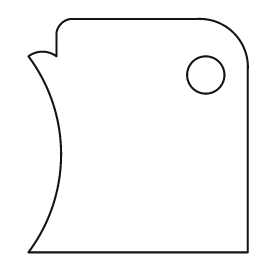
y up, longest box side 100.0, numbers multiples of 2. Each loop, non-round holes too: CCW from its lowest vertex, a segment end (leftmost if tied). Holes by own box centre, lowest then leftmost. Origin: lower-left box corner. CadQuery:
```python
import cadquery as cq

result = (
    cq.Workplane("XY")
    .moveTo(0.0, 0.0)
    .lineTo(94.0, 0.0)
    .lineTo(94.0, 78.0)
    .threePointArc((88.0, 94.0), (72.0, 100.0))
    .lineTo(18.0, 100.0)
    .threePointArc((14.0, 98.0), (12.0, 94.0))
    .lineTo(12.0, 84.0)
    .threePointArc((6.0, 86.0), (0.0, 84.0))
    .threePointArc((14.0, 42.0), (0.0, 0.0))
    .close()
    .moveTo(76.0, 76.0)
    .circle(8.0)
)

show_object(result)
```